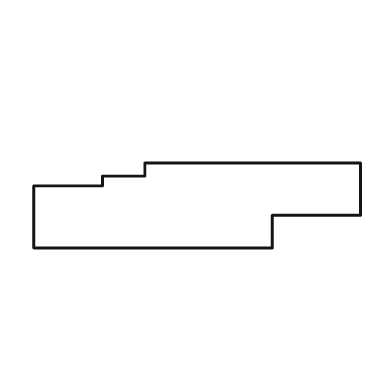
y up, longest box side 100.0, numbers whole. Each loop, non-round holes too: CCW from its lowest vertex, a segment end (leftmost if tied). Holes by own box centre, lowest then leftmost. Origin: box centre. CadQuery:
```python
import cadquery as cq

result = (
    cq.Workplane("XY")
    .moveTo(-50.0, -13.0)
    .lineTo(23.0, -13.0)
    .lineTo(23.0, -3.0)
    .lineTo(50.0, -3.0)
    .lineTo(50.0, 13.0)
    .lineTo(-16.0, 13.0)
    .lineTo(-16.0, 9.0)
    .lineTo(-29.0, 9.0)
    .lineTo(-29.0, 6.0)
    .lineTo(-50.0, 6.0)
    .close()
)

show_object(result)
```